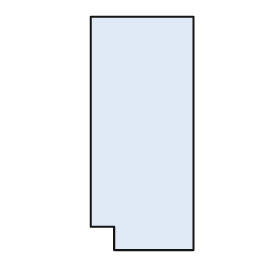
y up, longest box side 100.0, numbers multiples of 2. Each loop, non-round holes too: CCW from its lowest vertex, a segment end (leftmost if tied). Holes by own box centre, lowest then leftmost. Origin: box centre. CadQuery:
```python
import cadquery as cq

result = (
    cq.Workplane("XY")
    .moveTo(-12.0, -50.0)
    .lineTo(22.0, -50.0)
    .lineTo(22.0, 50.0)
    .lineTo(-22.0, 50.0)
    .lineTo(-22.0, -40.0)
    .lineTo(-12.0, -40.0)
    .close()
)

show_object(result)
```